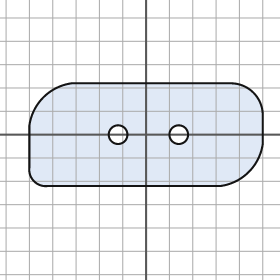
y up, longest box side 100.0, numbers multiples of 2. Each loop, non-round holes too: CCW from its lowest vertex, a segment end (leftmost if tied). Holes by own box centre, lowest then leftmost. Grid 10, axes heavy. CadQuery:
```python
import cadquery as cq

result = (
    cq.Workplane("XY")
    .moveTo(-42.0, -22.0)
    .lineTo(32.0, -22.0)
    .threePointArc((44.0, -16.0), (50.0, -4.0))
    .lineTo(50.0, 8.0)
    .threePointArc((46.0, 18.0), (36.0, 22.0))
    .lineTo(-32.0, 22.0)
    .threePointArc((-44.0, 16.0), (-50.0, 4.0))
    .lineTo(-50.0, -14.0)
    .threePointArc((-48.0, -20.0), (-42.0, -22.0))
    .close()
    .moveTo(-12.0, 0.0)
    .circle(4.0)
    .moveTo(14.0, 0.0)
    .circle(4.0)
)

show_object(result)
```